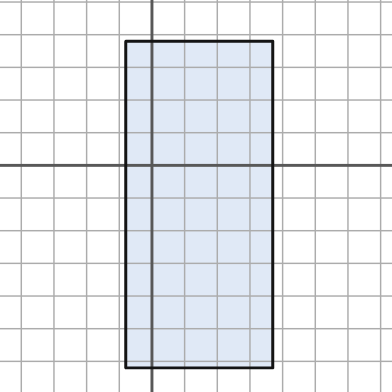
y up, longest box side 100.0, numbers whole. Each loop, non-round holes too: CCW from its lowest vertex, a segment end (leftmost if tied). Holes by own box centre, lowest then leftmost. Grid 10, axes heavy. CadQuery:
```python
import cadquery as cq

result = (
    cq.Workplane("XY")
    .moveTo(-8.0, -62.0)
    .lineTo(37.0, -62.0)
    .lineTo(37.0, 38.0)
    .lineTo(-8.0, 38.0)
    .close()
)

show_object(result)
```